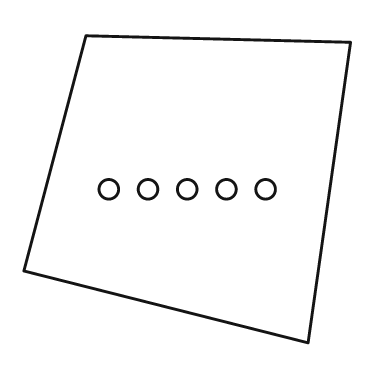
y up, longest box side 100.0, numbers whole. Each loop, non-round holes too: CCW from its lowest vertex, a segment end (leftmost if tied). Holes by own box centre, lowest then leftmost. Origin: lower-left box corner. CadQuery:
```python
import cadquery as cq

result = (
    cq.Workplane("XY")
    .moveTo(87.0, 0.0)
    .lineTo(100.0, 92.0)
    .lineTo(19.0, 94.0)
    .lineTo(0.0, 22.0)
    .close()
    .moveTo(26.0, 47.0)
    .circle(3.0)
    .moveTo(38.0, 47.0)
    .circle(3.0)
    .moveTo(50.0, 47.0)
    .circle(3.0)
    .moveTo(62.0, 47.0)
    .circle(3.0)
    .moveTo(74.0, 47.0)
    .circle(3.0)
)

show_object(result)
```